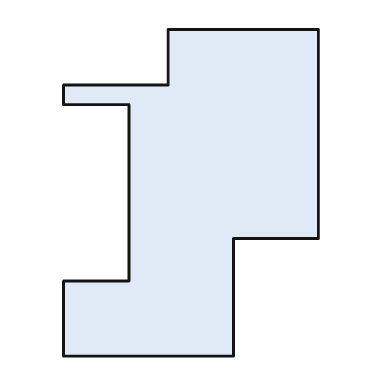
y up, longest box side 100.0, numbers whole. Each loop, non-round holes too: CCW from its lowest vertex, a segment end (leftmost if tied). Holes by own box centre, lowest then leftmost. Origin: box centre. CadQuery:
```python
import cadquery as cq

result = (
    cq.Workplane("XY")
    .moveTo(-39.0, -50.0)
    .lineTo(13.0, -50.0)
    .lineTo(13.0, -14.0)
    .lineTo(39.0, -14.0)
    .lineTo(39.0, 50.0)
    .lineTo(-7.0, 50.0)
    .lineTo(-7.0, 33.0)
    .lineTo(-39.0, 33.0)
    .lineTo(-39.0, 27.0)
    .lineTo(-19.0, 27.0)
    .lineTo(-19.0, -27.0)
    .lineTo(-39.0, -27.0)
    .close()
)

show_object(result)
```